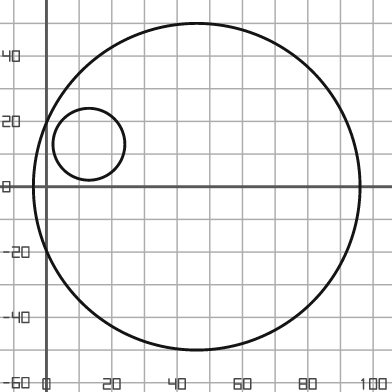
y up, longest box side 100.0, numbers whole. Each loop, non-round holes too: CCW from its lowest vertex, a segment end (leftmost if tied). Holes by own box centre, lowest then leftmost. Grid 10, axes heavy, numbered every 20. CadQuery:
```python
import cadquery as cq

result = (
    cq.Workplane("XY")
    .moveTo(46.0, 0.0)
    .circle(50.0)
    .moveTo(13.0, 13.0)
    .circle(11.0)
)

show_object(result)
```